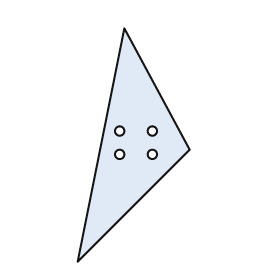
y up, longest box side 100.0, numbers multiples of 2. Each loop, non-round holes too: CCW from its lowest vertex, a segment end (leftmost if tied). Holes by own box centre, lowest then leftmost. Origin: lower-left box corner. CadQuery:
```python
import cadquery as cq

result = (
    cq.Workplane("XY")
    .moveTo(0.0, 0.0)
    .lineTo(48.0, 48.0)
    .lineTo(20.0, 100.0)
    .close()
    .moveTo(18.0, 46.0)
    .circle(2.0)
    .moveTo(32.0, 46.0)
    .circle(2.0)
    .moveTo(18.0, 56.0)
    .circle(2.0)
    .moveTo(32.0, 56.0)
    .circle(2.0)
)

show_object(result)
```